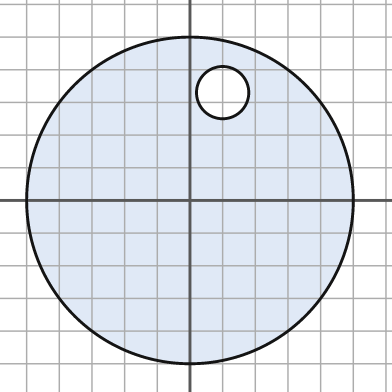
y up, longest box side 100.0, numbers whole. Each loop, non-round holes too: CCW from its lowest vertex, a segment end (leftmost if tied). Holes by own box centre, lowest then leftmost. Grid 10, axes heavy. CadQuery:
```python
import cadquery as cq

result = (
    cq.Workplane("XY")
    .moveTo(0.0, 0.0)
    .circle(50.0)
    .moveTo(10.0, 33.0)
    .circle(8.0)
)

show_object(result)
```